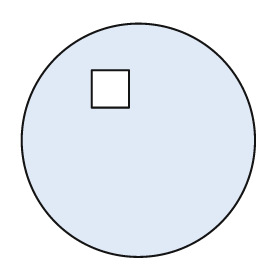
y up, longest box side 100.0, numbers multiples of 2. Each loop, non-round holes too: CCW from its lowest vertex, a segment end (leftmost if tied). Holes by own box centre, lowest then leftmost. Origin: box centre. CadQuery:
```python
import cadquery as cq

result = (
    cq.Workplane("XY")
    .moveTo(0.0, 0.0)
    .circle(50.0)
    .moveTo(-20.0, 14.0)
    .lineTo(-4.0, 14.0)
    .lineTo(-4.0, 30.0)
    .lineTo(-20.0, 30.0)
    .close()
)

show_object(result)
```